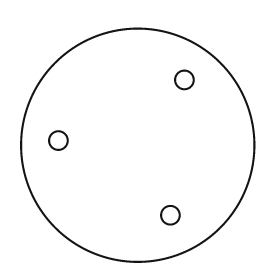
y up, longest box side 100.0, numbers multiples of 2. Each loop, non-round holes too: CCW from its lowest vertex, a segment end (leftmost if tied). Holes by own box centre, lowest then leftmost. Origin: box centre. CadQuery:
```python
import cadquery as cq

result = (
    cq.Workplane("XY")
    .moveTo(0.0, 0.0)
    .circle(50.0)
    .moveTo(14.0, -30.0)
    .circle(4.0)
    .moveTo(-34.0, 2.0)
    .circle(4.0)
    .moveTo(20.0, 28.0)
    .circle(4.0)
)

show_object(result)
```